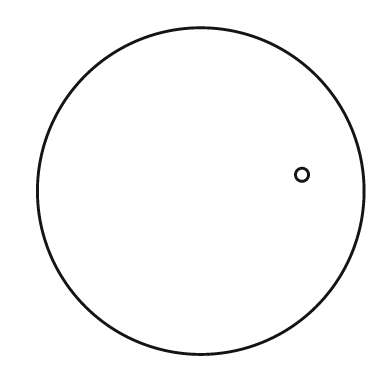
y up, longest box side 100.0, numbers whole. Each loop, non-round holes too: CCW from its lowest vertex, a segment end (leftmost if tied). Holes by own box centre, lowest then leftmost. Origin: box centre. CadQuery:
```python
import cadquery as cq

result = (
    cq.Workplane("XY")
    .moveTo(0.0, 0.0)
    .circle(50.0)
    .moveTo(31.0, 5.0)
    .circle(2.0)
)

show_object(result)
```